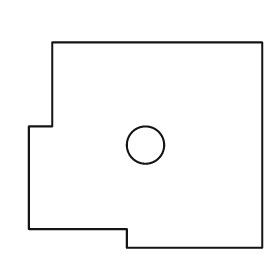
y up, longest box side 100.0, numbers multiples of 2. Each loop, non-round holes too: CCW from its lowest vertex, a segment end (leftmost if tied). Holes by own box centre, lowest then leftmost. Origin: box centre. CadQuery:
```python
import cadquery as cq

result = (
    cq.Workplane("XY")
    .moveTo(-8.0, -44.0)
    .lineTo(50.0, -44.0)
    .lineTo(50.0, 44.0)
    .lineTo(-40.0, 44.0)
    .lineTo(-40.0, 8.0)
    .lineTo(-50.0, 8.0)
    .lineTo(-50.0, -36.0)
    .lineTo(-8.0, -36.0)
    .close()
    .moveTo(0.0, 0.0)
    .circle(8.0)
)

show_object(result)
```